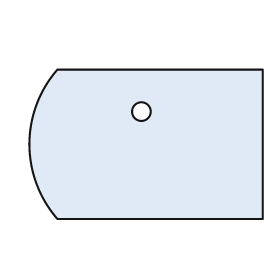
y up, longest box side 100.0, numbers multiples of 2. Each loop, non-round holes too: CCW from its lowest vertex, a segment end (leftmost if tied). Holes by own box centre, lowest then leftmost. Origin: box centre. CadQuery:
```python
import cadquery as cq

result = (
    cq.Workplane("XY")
    .moveTo(-38.0, -32.0)
    .lineTo(50.0, -32.0)
    .lineTo(50.0, 32.0)
    .lineTo(-38.0, 32.0)
    .threePointArc((-50.0, 0.0), (-38.0, -32.0))
    .close()
    .moveTo(-2.0, 14.0)
    .circle(4.0)
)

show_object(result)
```